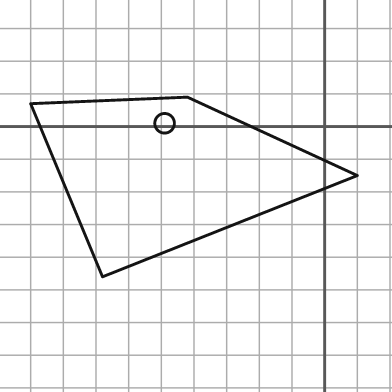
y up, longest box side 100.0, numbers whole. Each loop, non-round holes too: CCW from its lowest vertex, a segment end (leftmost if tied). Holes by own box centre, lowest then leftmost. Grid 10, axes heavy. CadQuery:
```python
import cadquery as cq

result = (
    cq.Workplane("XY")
    .moveTo(-68.0, -46.0)
    .lineTo(10.0, -15.0)
    .lineTo(-42.0, 9.0)
    .lineTo(-90.0, 7.0)
    .close()
    .moveTo(-49.0, 1.0)
    .circle(3.0)
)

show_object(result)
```